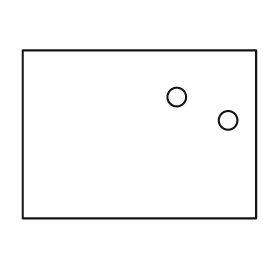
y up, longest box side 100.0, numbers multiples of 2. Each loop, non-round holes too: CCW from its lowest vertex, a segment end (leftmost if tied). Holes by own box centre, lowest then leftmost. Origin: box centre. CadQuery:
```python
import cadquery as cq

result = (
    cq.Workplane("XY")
    .moveTo(-50.0, -36.0)
    .lineTo(50.0, -36.0)
    .lineTo(50.0, 36.0)
    .lineTo(-50.0, 36.0)
    .close()
    .moveTo(38.0, 6.0)
    .circle(4.0)
    .moveTo(16.0, 16.0)
    .circle(4.0)
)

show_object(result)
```